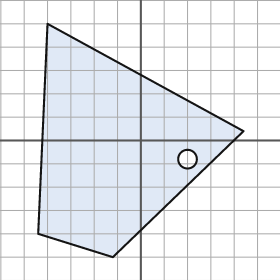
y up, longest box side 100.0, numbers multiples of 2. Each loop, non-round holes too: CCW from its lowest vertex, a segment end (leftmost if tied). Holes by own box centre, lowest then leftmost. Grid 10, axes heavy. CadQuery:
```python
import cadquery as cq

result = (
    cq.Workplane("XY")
    .moveTo(-12.0, -50.0)
    .lineTo(44.0, 4.0)
    .lineTo(-40.0, 50.0)
    .lineTo(-44.0, -40.0)
    .close()
    .moveTo(20.0, -8.0)
    .circle(4.0)
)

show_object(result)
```